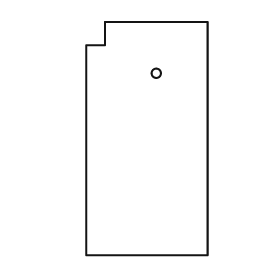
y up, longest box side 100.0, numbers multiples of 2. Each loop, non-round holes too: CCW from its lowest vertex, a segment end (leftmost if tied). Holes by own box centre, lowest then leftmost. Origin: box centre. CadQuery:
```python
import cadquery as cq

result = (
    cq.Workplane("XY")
    .moveTo(-26.0, -50.0)
    .lineTo(26.0, -50.0)
    .lineTo(26.0, 50.0)
    .lineTo(-18.0, 50.0)
    .lineTo(-18.0, 40.0)
    .lineTo(-26.0, 40.0)
    .close()
    .moveTo(4.0, 28.0)
    .circle(2.0)
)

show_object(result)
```